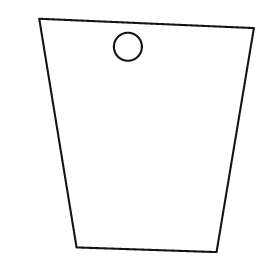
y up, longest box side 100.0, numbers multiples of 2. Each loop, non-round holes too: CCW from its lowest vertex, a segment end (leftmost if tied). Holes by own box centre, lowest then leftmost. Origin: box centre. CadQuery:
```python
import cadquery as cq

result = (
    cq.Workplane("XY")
    .moveTo(30.0, -50.0)
    .lineTo(46.0, 46.0)
    .lineTo(-46.0, 50.0)
    .lineTo(-30.0, -48.0)
    .close()
    .moveTo(-8.0, 38.0)
    .circle(6.0)
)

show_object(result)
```